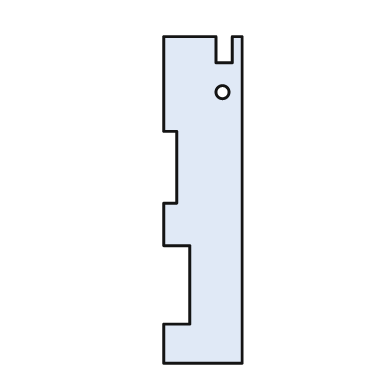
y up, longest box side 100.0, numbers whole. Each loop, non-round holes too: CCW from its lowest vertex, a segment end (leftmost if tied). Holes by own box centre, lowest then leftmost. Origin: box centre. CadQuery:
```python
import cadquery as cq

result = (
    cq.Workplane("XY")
    .moveTo(-12.0, -50.0)
    .lineTo(12.0, -50.0)
    .lineTo(12.0, 50.0)
    .lineTo(9.0, 50.0)
    .lineTo(9.0, 42.0)
    .lineTo(4.0, 42.0)
    .lineTo(4.0, 50.0)
    .lineTo(-12.0, 50.0)
    .lineTo(-12.0, 21.0)
    .lineTo(-8.0, 21.0)
    .lineTo(-8.0, -1.0)
    .lineTo(-12.0, -1.0)
    .lineTo(-12.0, -14.0)
    .lineTo(-4.0, -14.0)
    .lineTo(-4.0, -38.0)
    .lineTo(-12.0, -38.0)
    .close()
    .moveTo(6.0, 33.0)
    .circle(2.0)
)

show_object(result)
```